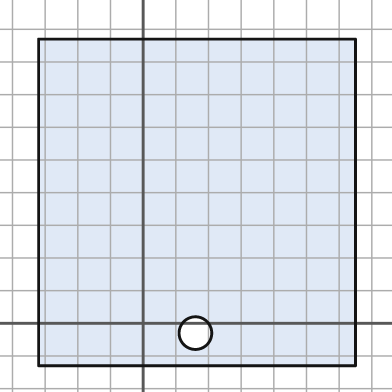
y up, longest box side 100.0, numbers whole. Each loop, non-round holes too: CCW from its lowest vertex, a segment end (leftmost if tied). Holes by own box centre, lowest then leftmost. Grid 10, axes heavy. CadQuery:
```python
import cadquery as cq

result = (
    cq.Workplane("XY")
    .moveTo(-32.0, -13.0)
    .lineTo(65.0, -13.0)
    .lineTo(65.0, 87.0)
    .lineTo(-32.0, 87.0)
    .close()
    .moveTo(16.0, -3.0)
    .circle(5.0)
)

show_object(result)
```